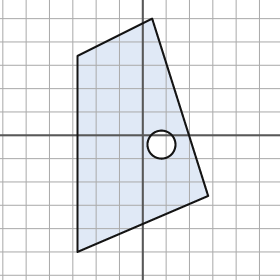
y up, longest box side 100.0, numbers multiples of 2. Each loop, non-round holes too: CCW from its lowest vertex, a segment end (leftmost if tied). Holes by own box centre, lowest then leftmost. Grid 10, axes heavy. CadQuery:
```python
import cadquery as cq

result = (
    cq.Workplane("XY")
    .moveTo(-28.0, -50.0)
    .lineTo(28.0, -26.0)
    .lineTo(4.0, 50.0)
    .lineTo(-28.0, 34.0)
    .close()
    .moveTo(8.0, -4.0)
    .circle(6.0)
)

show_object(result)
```